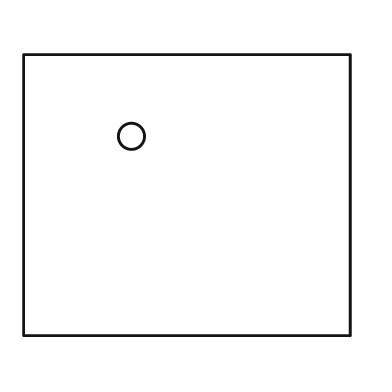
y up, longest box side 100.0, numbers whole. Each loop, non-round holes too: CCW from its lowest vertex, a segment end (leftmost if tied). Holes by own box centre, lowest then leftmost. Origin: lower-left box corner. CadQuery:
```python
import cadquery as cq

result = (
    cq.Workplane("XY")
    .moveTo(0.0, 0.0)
    .lineTo(100.0, 0.0)
    .lineTo(100.0, 86.0)
    .lineTo(0.0, 86.0)
    .close()
    .moveTo(33.0, 61.0)
    .circle(4.0)
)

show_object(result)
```